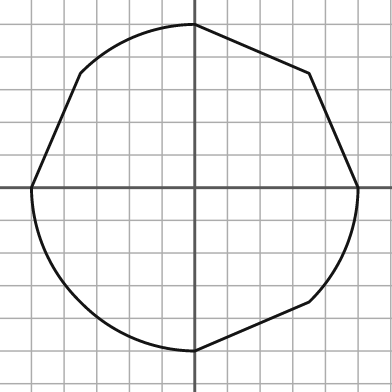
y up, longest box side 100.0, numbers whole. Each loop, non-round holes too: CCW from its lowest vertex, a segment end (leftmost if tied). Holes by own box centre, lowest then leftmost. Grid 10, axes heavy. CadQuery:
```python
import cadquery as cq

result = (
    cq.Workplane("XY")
    .moveTo(0.0, -50.0)
    .lineTo(35.0, -35.0)
    .threePointArc((46.0, -19.0), (50.0, 0.0))
    .lineTo(35.0, 35.0)
    .lineTo(0.0, 50.0)
    .threePointArc((-19.0, 46.0), (-35.0, 35.0))
    .lineTo(-50.0, 0.0)
    .threePointArc((-46.0, -19.0), (-35.0, -35.0))
    .threePointArc((-19.0, -46.0), (0.0, -50.0))
    .close()
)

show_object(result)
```